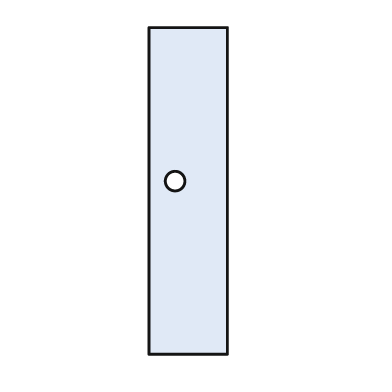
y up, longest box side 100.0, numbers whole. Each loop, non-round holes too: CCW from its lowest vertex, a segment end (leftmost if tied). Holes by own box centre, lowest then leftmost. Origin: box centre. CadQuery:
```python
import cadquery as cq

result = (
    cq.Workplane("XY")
    .moveTo(-12.0, -50.0)
    .lineTo(12.0, -50.0)
    .lineTo(12.0, 50.0)
    .lineTo(-12.0, 50.0)
    .close()
    .moveTo(-4.0, 3.0)
    .circle(3.0)
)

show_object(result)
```